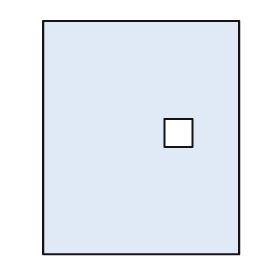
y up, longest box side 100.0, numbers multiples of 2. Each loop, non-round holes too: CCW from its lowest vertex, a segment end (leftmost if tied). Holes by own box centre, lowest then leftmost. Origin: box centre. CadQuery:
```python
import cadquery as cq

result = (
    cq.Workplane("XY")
    .moveTo(-42.0, -50.0)
    .lineTo(42.0, -50.0)
    .lineTo(42.0, 50.0)
    .lineTo(-42.0, 50.0)
    .close()
    .moveTo(10.0, -4.0)
    .lineTo(22.0, -4.0)
    .lineTo(22.0, 8.0)
    .lineTo(10.0, 8.0)
    .close()
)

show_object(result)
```